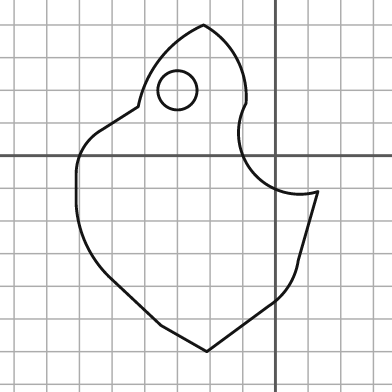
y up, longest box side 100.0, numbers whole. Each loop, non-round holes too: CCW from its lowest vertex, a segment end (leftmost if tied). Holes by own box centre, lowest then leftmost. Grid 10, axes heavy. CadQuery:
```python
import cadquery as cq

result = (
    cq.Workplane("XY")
    .moveTo(-21.0, -60.0)
    .lineTo(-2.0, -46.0)
    .threePointArc((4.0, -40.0), (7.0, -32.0))
    .lineTo(13.0, -11.0)
    .threePointArc((-7.0, -5.0), (-9.0, 16.0))
    .threePointArc((-12.0, 30.0), (-22.0, 40.0))
    .threePointArc((-35.0, 30.0), (-42.0, 15.0))
    .lineTo(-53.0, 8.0)
    .threePointArc((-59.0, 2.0), (-61.0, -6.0))
    .lineTo(-61.0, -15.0)
    .threePointArc((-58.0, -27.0), (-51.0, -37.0))
    .lineTo(-35.0, -52.0)
    .close()
    .moveTo(-30.0, 20.0)
    .circle(6.0)
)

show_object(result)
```